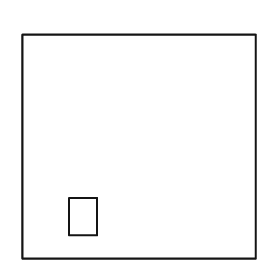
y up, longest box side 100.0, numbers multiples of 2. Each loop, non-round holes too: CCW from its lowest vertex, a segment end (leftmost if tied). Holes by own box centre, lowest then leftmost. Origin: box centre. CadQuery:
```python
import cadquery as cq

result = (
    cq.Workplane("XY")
    .moveTo(-50.0, -48.0)
    .lineTo(50.0, -48.0)
    .lineTo(50.0, 48.0)
    .lineTo(-50.0, 48.0)
    .close()
    .moveTo(-30.0, -38.0)
    .lineTo(-18.0, -38.0)
    .lineTo(-18.0, -22.0)
    .lineTo(-30.0, -22.0)
    .close()
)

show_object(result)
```